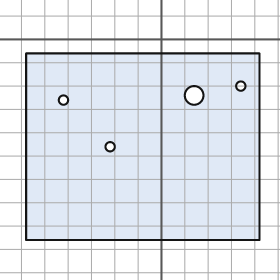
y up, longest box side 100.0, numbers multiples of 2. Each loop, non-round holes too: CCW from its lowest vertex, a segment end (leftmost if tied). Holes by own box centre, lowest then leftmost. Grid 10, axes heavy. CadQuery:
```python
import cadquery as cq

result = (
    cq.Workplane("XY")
    .moveTo(-58.0, -86.0)
    .lineTo(42.0, -86.0)
    .lineTo(42.0, -6.0)
    .lineTo(-58.0, -6.0)
    .close()
    .moveTo(-22.0, -46.0)
    .circle(2.0)
    .moveTo(-42.0, -26.0)
    .circle(2.0)
    .moveTo(14.0, -24.0)
    .circle(4.0)
    .moveTo(34.0, -20.0)
    .circle(2.0)
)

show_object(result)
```